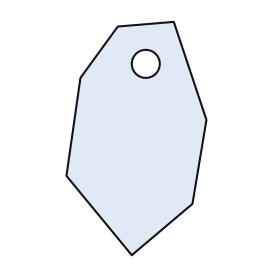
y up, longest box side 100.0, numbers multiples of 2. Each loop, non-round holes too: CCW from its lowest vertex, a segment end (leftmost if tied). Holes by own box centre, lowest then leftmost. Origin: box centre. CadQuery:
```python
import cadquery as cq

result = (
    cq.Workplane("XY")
    .moveTo(-2.0, -50.0)
    .lineTo(24.0, -28.0)
    .lineTo(30.0, 8.0)
    .lineTo(16.0, 50.0)
    .lineTo(-8.0, 48.0)
    .lineTo(-24.0, 26.0)
    .lineTo(-30.0, -16.0)
    .close()
    .moveTo(4.0, 32.0)
    .circle(6.0)
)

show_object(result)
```